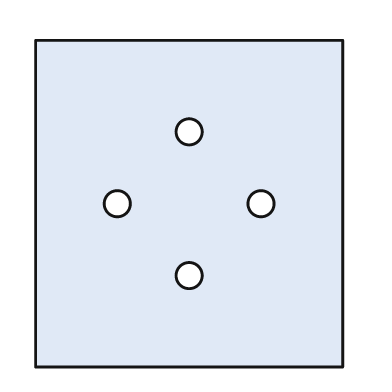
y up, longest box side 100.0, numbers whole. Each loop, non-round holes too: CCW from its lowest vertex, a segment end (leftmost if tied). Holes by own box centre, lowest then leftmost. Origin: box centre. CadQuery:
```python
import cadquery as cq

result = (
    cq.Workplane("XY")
    .moveTo(-47.0, -50.0)
    .lineTo(47.0, -50.0)
    .lineTo(47.0, 50.0)
    .lineTo(-47.0, 50.0)
    .close()
    .moveTo(0.0, -22.0)
    .circle(4.0)
    .moveTo(-22.0, 0.0)
    .circle(4.0)
    .moveTo(22.0, 0.0)
    .circle(4.0)
    .moveTo(0.0, 22.0)
    .circle(4.0)
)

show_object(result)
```